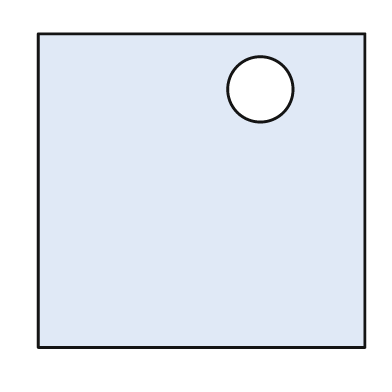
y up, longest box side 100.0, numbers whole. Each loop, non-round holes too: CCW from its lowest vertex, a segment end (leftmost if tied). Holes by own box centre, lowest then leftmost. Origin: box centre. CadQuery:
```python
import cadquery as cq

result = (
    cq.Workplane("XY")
    .moveTo(-50.0, -48.0)
    .lineTo(50.0, -48.0)
    .lineTo(50.0, 48.0)
    .lineTo(-50.0, 48.0)
    .close()
    .moveTo(18.0, 31.0)
    .circle(10.0)
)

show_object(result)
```